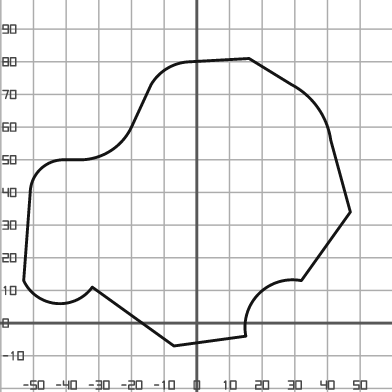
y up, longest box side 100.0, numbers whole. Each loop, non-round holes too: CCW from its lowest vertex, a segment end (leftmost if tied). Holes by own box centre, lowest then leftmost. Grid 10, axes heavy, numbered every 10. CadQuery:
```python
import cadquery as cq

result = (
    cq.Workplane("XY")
    .moveTo(-7.0, -7.0)
    .lineTo(15.0, -4.0)
    .threePointArc((19.0, 9.0), (32.0, 13.0))
    .lineTo(47.0, 34.0)
    .lineTo(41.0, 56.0)
    .threePointArc((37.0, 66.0), (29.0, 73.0))
    .lineTo(16.0, 81.0)
    .lineTo(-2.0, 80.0)
    .threePointArc((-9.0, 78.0), (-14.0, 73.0))
    .lineTo(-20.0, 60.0)
    .threePointArc((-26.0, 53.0), (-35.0, 50.0))
    .lineTo(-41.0, 50.0)
    .threePointArc((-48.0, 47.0), (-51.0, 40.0))
    .lineTo(-53.0, 13.0)
    .threePointArc((-43.0, 6.0), (-32.0, 11.0))
    .close()
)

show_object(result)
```